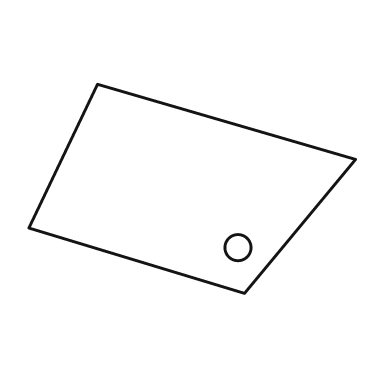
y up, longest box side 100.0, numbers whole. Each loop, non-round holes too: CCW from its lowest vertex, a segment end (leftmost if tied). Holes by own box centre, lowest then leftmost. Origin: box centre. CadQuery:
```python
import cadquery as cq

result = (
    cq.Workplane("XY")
    .moveTo(16.0, -32.0)
    .lineTo(50.0, 9.0)
    .lineTo(-29.0, 32.0)
    .lineTo(-50.0, -12.0)
    .close()
    .moveTo(14.0, -18.0)
    .circle(4.0)
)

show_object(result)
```